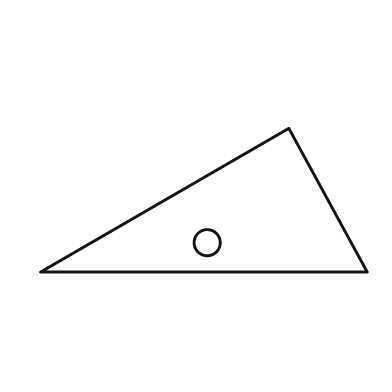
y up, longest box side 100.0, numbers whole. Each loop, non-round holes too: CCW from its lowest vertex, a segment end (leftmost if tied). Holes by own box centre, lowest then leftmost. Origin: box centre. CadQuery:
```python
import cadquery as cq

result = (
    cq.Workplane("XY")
    .moveTo(-50.0, -22.0)
    .lineTo(50.0, -22.0)
    .lineTo(26.0, 22.0)
    .close()
    .moveTo(1.0, -13.0)
    .circle(4.0)
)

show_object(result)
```